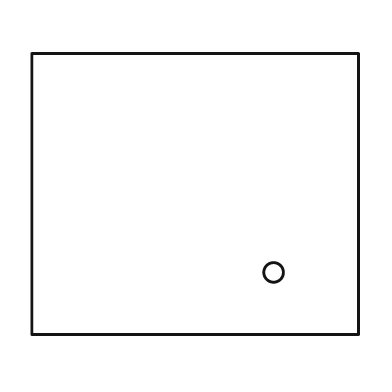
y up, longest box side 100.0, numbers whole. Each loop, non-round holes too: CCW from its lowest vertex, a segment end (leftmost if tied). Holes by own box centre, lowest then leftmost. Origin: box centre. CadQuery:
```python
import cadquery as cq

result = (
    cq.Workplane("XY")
    .moveTo(-50.0, -43.0)
    .lineTo(50.0, -43.0)
    .lineTo(50.0, 43.0)
    .lineTo(-50.0, 43.0)
    .close()
    .moveTo(24.0, -24.0)
    .circle(3.0)
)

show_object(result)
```